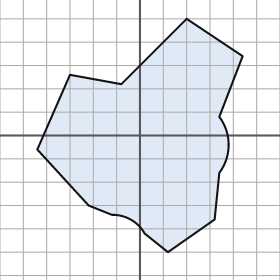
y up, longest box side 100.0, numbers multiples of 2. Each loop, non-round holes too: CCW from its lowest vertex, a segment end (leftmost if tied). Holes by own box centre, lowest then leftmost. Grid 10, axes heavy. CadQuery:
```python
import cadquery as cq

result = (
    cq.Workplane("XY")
    .moveTo(12.0, -50.0)
    .lineTo(32.0, -36.0)
    .lineTo(34.0, -16.0)
    .threePointArc((38.0, -4.0), (34.0, 8.0))
    .lineTo(44.0, 34.0)
    .lineTo(20.0, 50.0)
    .lineTo(-8.0, 22.0)
    .lineTo(-30.0, 26.0)
    .lineTo(-44.0, -6.0)
    .lineTo(-22.0, -30.0)
    .lineTo(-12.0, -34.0)
    .threePointArc((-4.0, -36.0), (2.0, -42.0))
    .close()
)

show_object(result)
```